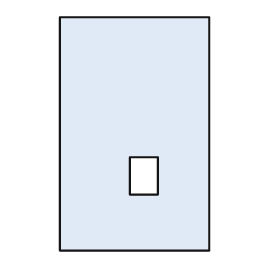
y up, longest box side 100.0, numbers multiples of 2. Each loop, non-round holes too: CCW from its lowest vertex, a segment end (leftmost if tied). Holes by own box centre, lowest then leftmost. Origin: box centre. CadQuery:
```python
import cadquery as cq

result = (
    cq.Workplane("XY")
    .moveTo(-32.0, -50.0)
    .lineTo(32.0, -50.0)
    .lineTo(32.0, 50.0)
    .lineTo(-32.0, 50.0)
    .close()
    .moveTo(-2.0, -26.0)
    .lineTo(10.0, -26.0)
    .lineTo(10.0, -10.0)
    .lineTo(-2.0, -10.0)
    .close()
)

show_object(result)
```